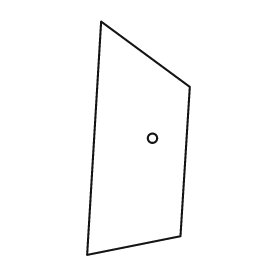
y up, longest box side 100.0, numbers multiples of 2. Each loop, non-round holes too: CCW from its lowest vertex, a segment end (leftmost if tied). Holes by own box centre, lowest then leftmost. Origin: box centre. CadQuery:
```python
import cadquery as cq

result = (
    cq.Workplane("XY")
    .moveTo(-22.0, -50.0)
    .lineTo(18.0, -42.0)
    .lineTo(22.0, 22.0)
    .lineTo(-16.0, 50.0)
    .close()
    .moveTo(6.0, 0.0)
    .circle(2.0)
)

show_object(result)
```